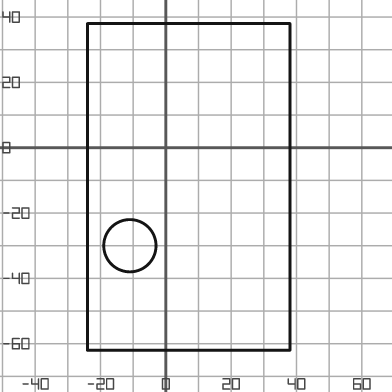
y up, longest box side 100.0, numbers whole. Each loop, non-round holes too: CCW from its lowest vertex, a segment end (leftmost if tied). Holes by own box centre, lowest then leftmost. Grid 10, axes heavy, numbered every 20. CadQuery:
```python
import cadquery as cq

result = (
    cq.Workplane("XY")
    .moveTo(-24.0, -62.0)
    .lineTo(38.0, -62.0)
    .lineTo(38.0, 38.0)
    .lineTo(-24.0, 38.0)
    .close()
    .moveTo(-11.0, -30.0)
    .circle(8.0)
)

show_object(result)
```